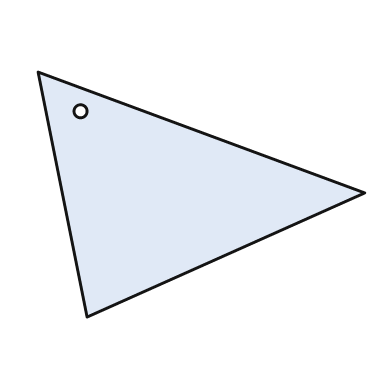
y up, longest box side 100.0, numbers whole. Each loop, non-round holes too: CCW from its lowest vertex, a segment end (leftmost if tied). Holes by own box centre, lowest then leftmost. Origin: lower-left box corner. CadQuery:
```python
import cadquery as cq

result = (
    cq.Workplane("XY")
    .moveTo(15.0, 0.0)
    .lineTo(100.0, 38.0)
    .lineTo(0.0, 75.0)
    .close()
    .moveTo(13.0, 63.0)
    .circle(2.0)
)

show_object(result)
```